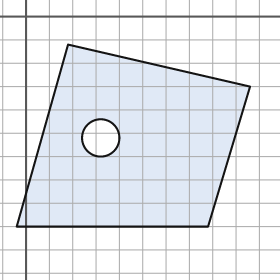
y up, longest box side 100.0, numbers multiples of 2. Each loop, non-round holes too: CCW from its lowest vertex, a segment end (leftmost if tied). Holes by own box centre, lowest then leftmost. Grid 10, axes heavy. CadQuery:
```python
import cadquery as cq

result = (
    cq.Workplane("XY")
    .moveTo(-4.0, -90.0)
    .lineTo(78.0, -90.0)
    .lineTo(96.0, -30.0)
    .lineTo(18.0, -12.0)
    .close()
    .moveTo(32.0, -52.0)
    .circle(8.0)
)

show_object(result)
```